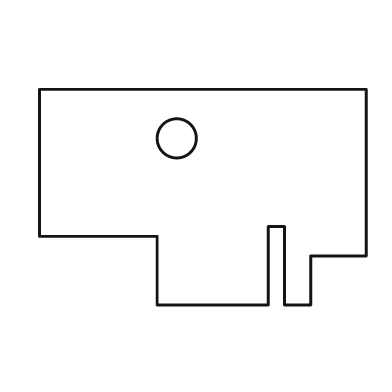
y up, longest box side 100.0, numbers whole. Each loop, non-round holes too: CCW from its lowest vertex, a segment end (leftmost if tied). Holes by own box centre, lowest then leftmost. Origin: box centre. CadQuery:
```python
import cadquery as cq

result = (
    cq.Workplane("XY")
    .moveTo(-14.0, -33.0)
    .lineTo(20.0, -33.0)
    .lineTo(20.0, -9.0)
    .lineTo(25.0, -9.0)
    .lineTo(25.0, -33.0)
    .lineTo(33.0, -33.0)
    .lineTo(33.0, -18.0)
    .lineTo(50.0, -18.0)
    .lineTo(50.0, 33.0)
    .lineTo(-50.0, 33.0)
    .lineTo(-50.0, -12.0)
    .lineTo(-14.0, -12.0)
    .close()
    .moveTo(-8.0, 18.0)
    .circle(6.0)
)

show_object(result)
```